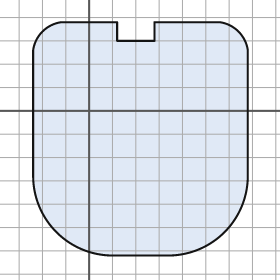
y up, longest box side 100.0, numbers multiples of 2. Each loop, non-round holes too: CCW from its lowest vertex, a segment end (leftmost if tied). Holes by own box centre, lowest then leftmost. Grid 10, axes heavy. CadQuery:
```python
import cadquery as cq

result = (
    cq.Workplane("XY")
    .moveTo(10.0, -62.0)
    .lineTo(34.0, -62.0)
    .threePointArc((58.0, -52.0), (68.0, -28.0))
    .lineTo(68.0, 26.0)
    .threePointArc((64.0, 34.0), (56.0, 38.0))
    .lineTo(28.0, 38.0)
    .lineTo(28.0, 30.0)
    .lineTo(12.0, 30.0)
    .lineTo(12.0, 38.0)
    .lineTo(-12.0, 38.0)
    .threePointArc((-20.0, 34.0), (-24.0, 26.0))
    .lineTo(-24.0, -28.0)
    .threePointArc((-14.0, -52.0), (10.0, -62.0))
    .close()
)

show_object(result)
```